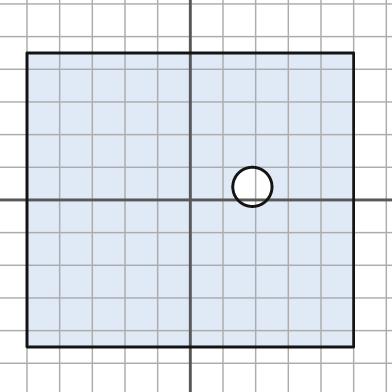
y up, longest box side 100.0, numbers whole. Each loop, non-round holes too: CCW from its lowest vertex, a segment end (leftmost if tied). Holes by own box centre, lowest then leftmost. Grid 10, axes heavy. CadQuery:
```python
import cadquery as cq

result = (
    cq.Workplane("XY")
    .moveTo(-50.0, -45.0)
    .lineTo(50.0, -45.0)
    .lineTo(50.0, 45.0)
    .lineTo(-50.0, 45.0)
    .close()
    .moveTo(19.0, 4.0)
    .circle(6.0)
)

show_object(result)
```